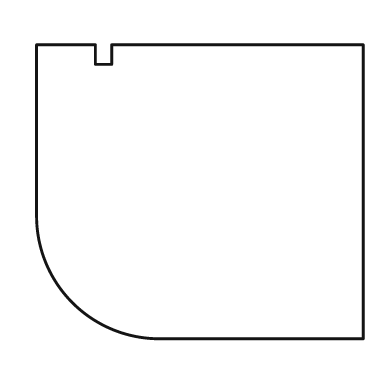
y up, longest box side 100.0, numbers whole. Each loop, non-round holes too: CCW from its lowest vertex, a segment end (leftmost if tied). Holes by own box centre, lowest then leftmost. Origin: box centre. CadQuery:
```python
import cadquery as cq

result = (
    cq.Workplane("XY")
    .moveTo(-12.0, -45.0)
    .lineTo(50.0, -45.0)
    .lineTo(50.0, 45.0)
    .lineTo(-27.0, 45.0)
    .lineTo(-27.0, 39.0)
    .lineTo(-32.0, 39.0)
    .lineTo(-32.0, 45.0)
    .lineTo(-50.0, 45.0)
    .lineTo(-50.0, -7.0)
    .threePointArc((-39.0, -34.0), (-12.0, -45.0))
    .close()
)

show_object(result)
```